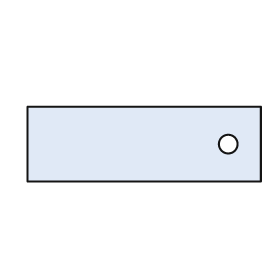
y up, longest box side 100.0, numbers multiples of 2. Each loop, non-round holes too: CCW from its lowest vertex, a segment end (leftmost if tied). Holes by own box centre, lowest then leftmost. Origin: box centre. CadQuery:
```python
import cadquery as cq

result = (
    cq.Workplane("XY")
    .moveTo(-50.0, -16.0)
    .lineTo(50.0, -16.0)
    .lineTo(50.0, 16.0)
    .lineTo(-50.0, 16.0)
    .close()
    .moveTo(36.0, 0.0)
    .circle(4.0)
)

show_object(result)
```